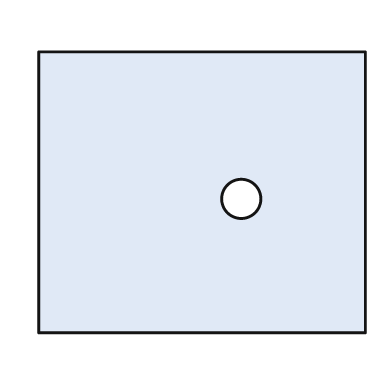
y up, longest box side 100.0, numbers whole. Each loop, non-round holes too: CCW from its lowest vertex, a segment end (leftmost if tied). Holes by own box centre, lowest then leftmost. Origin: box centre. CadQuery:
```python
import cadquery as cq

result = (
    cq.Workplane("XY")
    .moveTo(-50.0, -43.0)
    .lineTo(50.0, -43.0)
    .lineTo(50.0, 43.0)
    .lineTo(-50.0, 43.0)
    .close()
    .moveTo(12.0, -2.0)
    .circle(6.0)
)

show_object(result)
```